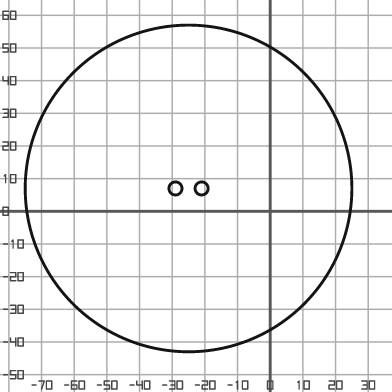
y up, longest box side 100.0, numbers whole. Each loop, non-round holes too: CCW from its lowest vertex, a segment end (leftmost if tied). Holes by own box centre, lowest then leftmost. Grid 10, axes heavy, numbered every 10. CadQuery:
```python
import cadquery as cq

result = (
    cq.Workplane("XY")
    .moveTo(-25.0, 7.0)
    .circle(50.0)
    .moveTo(-29.0, 7.0)
    .circle(2.0)
    .moveTo(-21.0, 7.0)
    .circle(2.0)
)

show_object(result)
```